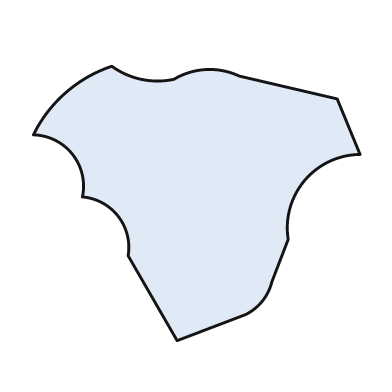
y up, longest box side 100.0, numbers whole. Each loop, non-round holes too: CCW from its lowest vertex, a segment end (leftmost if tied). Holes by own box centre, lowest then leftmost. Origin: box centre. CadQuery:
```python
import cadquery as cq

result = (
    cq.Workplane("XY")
    .moveTo(-6.0, -42.0)
    .lineTo(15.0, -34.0)
    .threePointArc((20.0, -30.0), (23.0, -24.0))
    .lineTo(28.0, -11.0)
    .threePointArc((33.0, 7.0), (50.0, 15.0))
    .lineTo(43.0, 32.0)
    .lineTo(13.0, 39.0)
    .threePointArc((3.0, 41.0), (-7.0, 38.0))
    .threePointArc((-17.0, 38.0), (-26.0, 42.0))
    .threePointArc((-40.0, 34.0), (-50.0, 21.0))
    .threePointArc((-38.0, 15.0), (-35.0, 2.0))
    .threePointArc((-24.0, -4.0), (-21.0, -16.0))
    .close()
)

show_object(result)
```